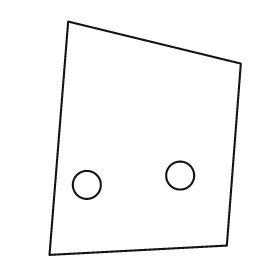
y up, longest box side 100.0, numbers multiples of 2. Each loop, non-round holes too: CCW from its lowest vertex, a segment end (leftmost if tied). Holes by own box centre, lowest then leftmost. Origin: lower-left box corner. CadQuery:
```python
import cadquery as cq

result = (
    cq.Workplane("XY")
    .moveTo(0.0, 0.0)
    .lineTo(76.0, 4.0)
    .lineTo(82.0, 82.0)
    .lineTo(8.0, 100.0)
    .close()
    .moveTo(16.0, 30.0)
    .circle(6.0)
    .moveTo(56.0, 34.0)
    .circle(6.0)
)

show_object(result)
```